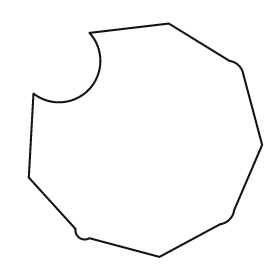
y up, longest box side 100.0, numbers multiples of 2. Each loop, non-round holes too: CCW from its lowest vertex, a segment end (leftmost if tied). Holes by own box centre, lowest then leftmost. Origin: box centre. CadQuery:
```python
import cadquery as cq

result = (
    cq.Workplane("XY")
    .moveTo(6.0, -50.0)
    .lineTo(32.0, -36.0)
    .threePointArc((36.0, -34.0), (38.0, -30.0))
    .lineTo(50.0, -2.0)
    .lineTo(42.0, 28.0)
    .threePointArc((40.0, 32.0), (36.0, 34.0))
    .lineTo(10.0, 50.0)
    .lineTo(-24.0, 46.0)
    .threePointArc((-24.0, 22.0), (-48.0, 20.0))
    .lineTo(-50.0, -16.0)
    .lineTo(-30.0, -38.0)
    .threePointArc((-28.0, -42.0), (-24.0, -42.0))
    .close()
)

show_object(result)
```